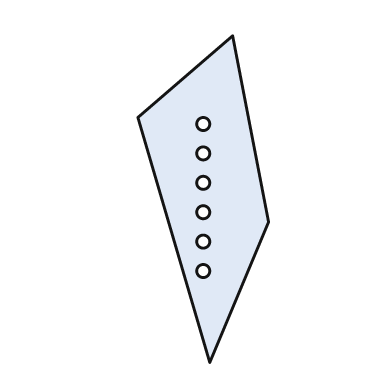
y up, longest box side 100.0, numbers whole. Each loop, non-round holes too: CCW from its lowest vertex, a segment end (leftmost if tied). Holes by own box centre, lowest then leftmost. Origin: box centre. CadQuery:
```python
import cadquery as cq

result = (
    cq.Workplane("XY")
    .moveTo(2.0, -50.0)
    .lineTo(20.0, -7.0)
    .lineTo(9.0, 50.0)
    .lineTo(-20.0, 25.0)
    .close()
    .moveTo(0.0, -22.0)
    .circle(2.0)
    .moveTo(0.0, -13.0)
    .circle(2.0)
    .moveTo(0.0, -4.0)
    .circle(2.0)
    .moveTo(0.0, 5.0)
    .circle(2.0)
    .moveTo(0.0, 14.0)
    .circle(2.0)
    .moveTo(0.0, 23.0)
    .circle(2.0)
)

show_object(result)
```